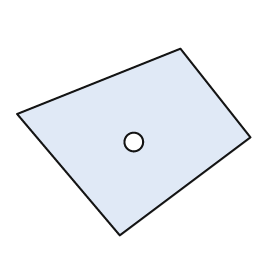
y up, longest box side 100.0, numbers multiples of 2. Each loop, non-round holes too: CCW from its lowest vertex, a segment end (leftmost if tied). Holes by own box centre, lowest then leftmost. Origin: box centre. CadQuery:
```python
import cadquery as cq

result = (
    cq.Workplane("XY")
    .moveTo(-6.0, -40.0)
    .lineTo(50.0, 2.0)
    .lineTo(20.0, 40.0)
    .lineTo(-50.0, 12.0)
    .close()
    .moveTo(0.0, 0.0)
    .circle(4.0)
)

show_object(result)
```